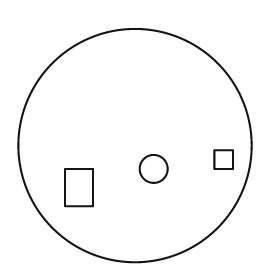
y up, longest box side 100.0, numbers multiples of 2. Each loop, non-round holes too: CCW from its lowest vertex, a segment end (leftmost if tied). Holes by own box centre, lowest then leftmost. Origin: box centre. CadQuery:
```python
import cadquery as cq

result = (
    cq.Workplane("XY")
    .moveTo(0.0, 0.0)
    .circle(50.0)
    .moveTo(-30.0, -26.0)
    .lineTo(-18.0, -26.0)
    .lineTo(-18.0, -10.0)
    .lineTo(-30.0, -10.0)
    .close()
    .moveTo(8.0, -10.0)
    .circle(6.0)
    .moveTo(34.0, -10.0)
    .lineTo(42.0, -10.0)
    .lineTo(42.0, -2.0)
    .lineTo(34.0, -2.0)
    .close()
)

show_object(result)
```